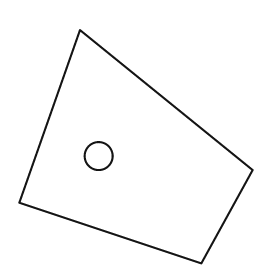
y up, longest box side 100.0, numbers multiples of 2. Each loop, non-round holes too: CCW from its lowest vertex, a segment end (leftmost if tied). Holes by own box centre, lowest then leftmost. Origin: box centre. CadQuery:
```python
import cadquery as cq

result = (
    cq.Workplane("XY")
    .moveTo(28.0, -50.0)
    .lineTo(50.0, -10.0)
    .lineTo(-24.0, 50.0)
    .lineTo(-50.0, -24.0)
    .close()
    .moveTo(-16.0, -4.0)
    .circle(6.0)
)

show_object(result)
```